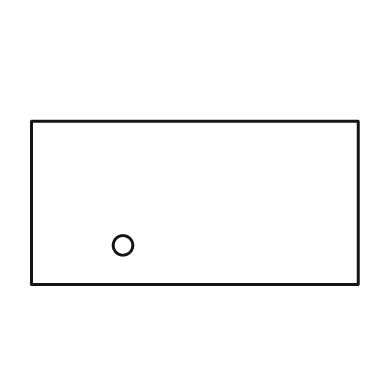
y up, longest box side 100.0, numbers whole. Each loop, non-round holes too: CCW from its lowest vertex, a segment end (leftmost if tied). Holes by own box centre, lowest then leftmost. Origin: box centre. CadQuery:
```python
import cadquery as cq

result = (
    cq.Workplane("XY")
    .moveTo(-50.0, -25.0)
    .lineTo(50.0, -25.0)
    .lineTo(50.0, 25.0)
    .lineTo(-50.0, 25.0)
    .close()
    .moveTo(-22.0, -13.0)
    .circle(3.0)
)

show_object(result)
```